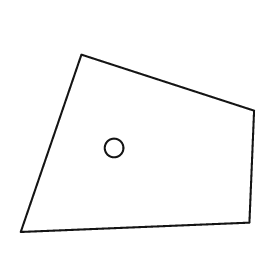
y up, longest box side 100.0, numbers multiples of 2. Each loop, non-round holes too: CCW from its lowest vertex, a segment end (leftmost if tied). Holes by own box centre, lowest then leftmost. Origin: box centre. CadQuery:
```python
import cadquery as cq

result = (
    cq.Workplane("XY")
    .moveTo(-50.0, -38.0)
    .lineTo(48.0, -34.0)
    .lineTo(50.0, 14.0)
    .lineTo(-24.0, 38.0)
    .close()
    .moveTo(-10.0, -2.0)
    .circle(4.0)
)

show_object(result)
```